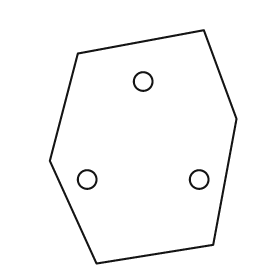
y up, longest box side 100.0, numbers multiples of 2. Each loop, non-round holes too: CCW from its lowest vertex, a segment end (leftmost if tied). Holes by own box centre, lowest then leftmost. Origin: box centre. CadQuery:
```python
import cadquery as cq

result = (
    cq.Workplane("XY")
    .moveTo(-20.0, -50.0)
    .lineTo(30.0, -42.0)
    .lineTo(40.0, 12.0)
    .lineTo(26.0, 50.0)
    .lineTo(-28.0, 40.0)
    .lineTo(-40.0, -6.0)
    .close()
    .moveTo(-24.0, -14.0)
    .circle(4.0)
    .moveTo(24.0, -14.0)
    .circle(4.0)
    .moveTo(0.0, 28.0)
    .circle(4.0)
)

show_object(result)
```